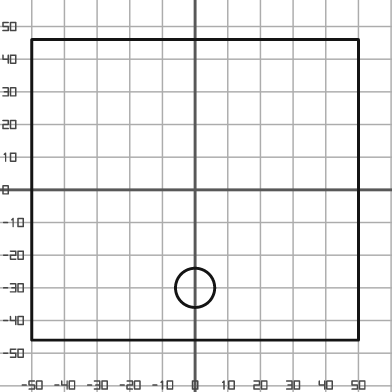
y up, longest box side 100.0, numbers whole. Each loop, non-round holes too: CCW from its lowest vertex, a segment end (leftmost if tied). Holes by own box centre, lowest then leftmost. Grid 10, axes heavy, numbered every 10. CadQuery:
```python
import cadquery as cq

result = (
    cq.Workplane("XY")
    .moveTo(-50.0, -46.0)
    .lineTo(50.0, -46.0)
    .lineTo(50.0, 46.0)
    .lineTo(-50.0, 46.0)
    .close()
    .moveTo(0.0, -30.0)
    .circle(6.0)
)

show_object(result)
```